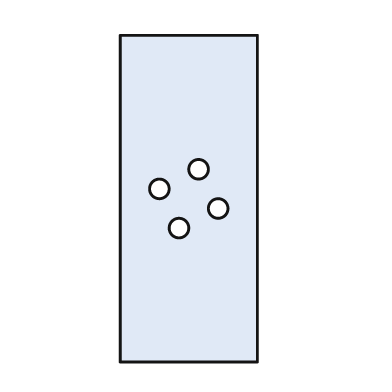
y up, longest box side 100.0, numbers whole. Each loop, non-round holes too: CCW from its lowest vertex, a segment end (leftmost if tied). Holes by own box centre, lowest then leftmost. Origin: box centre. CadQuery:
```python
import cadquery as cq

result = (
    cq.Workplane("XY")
    .moveTo(-21.0, -50.0)
    .lineTo(21.0, -50.0)
    .lineTo(21.0, 50.0)
    .lineTo(-21.0, 50.0)
    .close()
    .moveTo(-3.0, -9.0)
    .circle(3.0)
    .moveTo(9.0, -3.0)
    .circle(3.0)
    .moveTo(-9.0, 3.0)
    .circle(3.0)
    .moveTo(3.0, 9.0)
    .circle(3.0)
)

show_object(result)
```